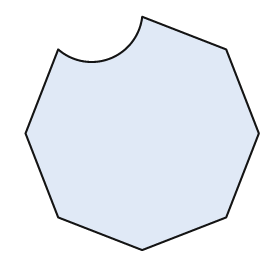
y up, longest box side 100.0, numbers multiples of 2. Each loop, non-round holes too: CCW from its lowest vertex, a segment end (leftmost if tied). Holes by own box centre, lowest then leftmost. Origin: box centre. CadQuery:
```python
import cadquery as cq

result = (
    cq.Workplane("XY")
    .moveTo(0.0, -50.0)
    .lineTo(36.0, -36.0)
    .lineTo(50.0, 0.0)
    .lineTo(36.0, 36.0)
    .lineTo(0.0, 50.0)
    .threePointArc((-14.0, 32.0), (-36.0, 36.0))
    .lineTo(-50.0, 0.0)
    .lineTo(-36.0, -36.0)
    .close()
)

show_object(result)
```